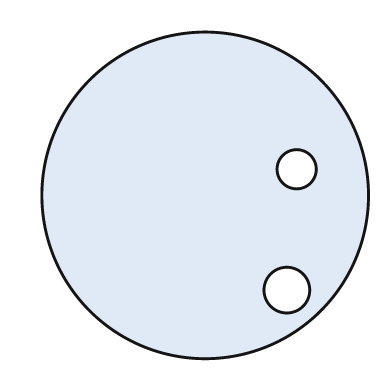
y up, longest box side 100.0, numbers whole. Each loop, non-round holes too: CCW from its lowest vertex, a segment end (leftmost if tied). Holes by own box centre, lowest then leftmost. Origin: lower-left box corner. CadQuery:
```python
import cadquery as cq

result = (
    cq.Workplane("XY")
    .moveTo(50.0, 50.0)
    .circle(50.0)
    .moveTo(75.0, 21.0)
    .circle(7.0)
    .moveTo(78.0, 58.0)
    .circle(6.0)
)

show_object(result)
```